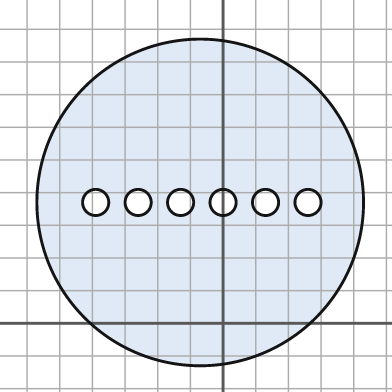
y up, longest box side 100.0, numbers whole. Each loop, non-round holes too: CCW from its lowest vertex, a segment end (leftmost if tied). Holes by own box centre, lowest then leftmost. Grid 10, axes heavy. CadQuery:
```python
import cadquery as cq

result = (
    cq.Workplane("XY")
    .moveTo(-7.0, 37.0)
    .circle(50.0)
    .moveTo(-39.0, 37.0)
    .circle(4.0)
    .moveTo(-26.0, 37.0)
    .circle(4.0)
    .moveTo(-13.0, 37.0)
    .circle(4.0)
    .moveTo(0.0, 37.0)
    .circle(4.0)
    .moveTo(13.0, 37.0)
    .circle(4.0)
    .moveTo(26.0, 37.0)
    .circle(4.0)
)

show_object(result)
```